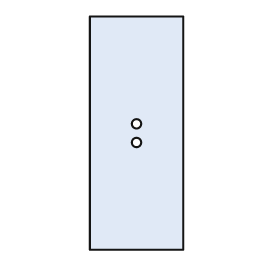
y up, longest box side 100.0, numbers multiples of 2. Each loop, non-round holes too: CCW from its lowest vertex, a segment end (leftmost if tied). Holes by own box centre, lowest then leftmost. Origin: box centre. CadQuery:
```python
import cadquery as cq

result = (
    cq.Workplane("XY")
    .moveTo(-20.0, -50.0)
    .lineTo(20.0, -50.0)
    .lineTo(20.0, 50.0)
    .lineTo(-20.0, 50.0)
    .close()
    .moveTo(0.0, -4.0)
    .circle(2.0)
    .moveTo(0.0, 4.0)
    .circle(2.0)
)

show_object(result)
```